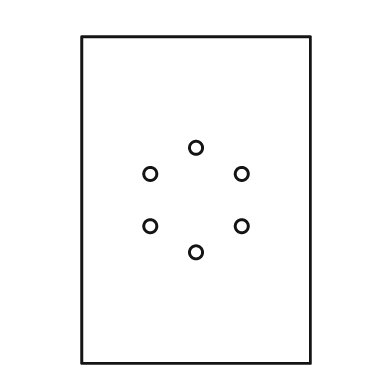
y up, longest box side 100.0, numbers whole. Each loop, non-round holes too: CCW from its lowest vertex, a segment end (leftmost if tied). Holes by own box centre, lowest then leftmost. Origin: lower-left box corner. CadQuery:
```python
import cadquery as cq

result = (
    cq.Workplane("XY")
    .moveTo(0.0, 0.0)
    .lineTo(70.0, 0.0)
    .lineTo(70.0, 100.0)
    .lineTo(0.0, 100.0)
    .close()
    .moveTo(35.0, 34.0)
    .circle(2.0)
    .moveTo(21.0, 42.0)
    .circle(2.0)
    .moveTo(49.0, 42.0)
    .circle(2.0)
    .moveTo(21.0, 58.0)
    .circle(2.0)
    .moveTo(49.0, 58.0)
    .circle(2.0)
    .moveTo(35.0, 66.0)
    .circle(2.0)
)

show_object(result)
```